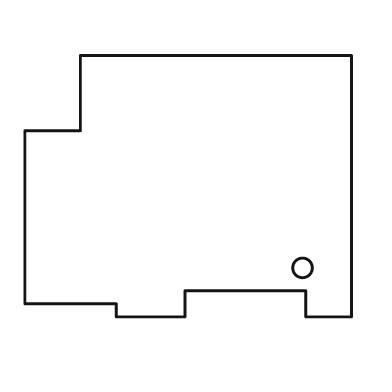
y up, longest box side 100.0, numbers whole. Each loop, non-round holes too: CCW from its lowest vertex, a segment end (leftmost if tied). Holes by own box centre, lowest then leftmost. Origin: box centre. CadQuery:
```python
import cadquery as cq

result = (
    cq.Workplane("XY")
    .moveTo(-22.0, -40.0)
    .lineTo(-1.0, -40.0)
    .lineTo(-1.0, -32.0)
    .lineTo(36.0, -32.0)
    .lineTo(36.0, -40.0)
    .lineTo(50.0, -40.0)
    .lineTo(50.0, 40.0)
    .lineTo(-33.0, 40.0)
    .lineTo(-33.0, 17.0)
    .lineTo(-50.0, 17.0)
    .lineTo(-50.0, -36.0)
    .lineTo(-22.0, -36.0)
    .close()
    .moveTo(35.0, -25.0)
    .circle(3.0)
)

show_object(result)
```